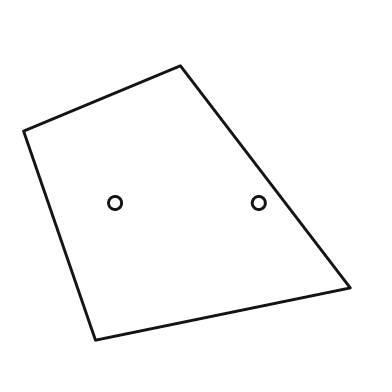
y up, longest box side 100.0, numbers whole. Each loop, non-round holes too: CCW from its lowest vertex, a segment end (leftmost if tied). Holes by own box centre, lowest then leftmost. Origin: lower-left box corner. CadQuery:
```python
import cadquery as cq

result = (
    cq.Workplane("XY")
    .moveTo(22.0, 0.0)
    .lineTo(100.0, 16.0)
    .lineTo(48.0, 84.0)
    .lineTo(0.0, 64.0)
    .close()
    .moveTo(28.0, 42.0)
    .circle(2.0)
    .moveTo(72.0, 42.0)
    .circle(2.0)
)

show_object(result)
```